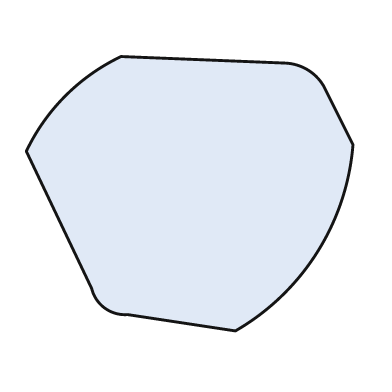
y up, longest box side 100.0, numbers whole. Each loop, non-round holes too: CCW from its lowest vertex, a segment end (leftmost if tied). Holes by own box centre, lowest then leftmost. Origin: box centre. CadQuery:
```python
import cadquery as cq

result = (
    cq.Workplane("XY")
    .moveTo(14.0, -42.0)
    .threePointArc((39.0, -18.0), (50.0, 15.0))
    .lineTo(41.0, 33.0)
    .threePointArc((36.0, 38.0), (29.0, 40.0))
    .lineTo(-21.0, 42.0)
    .threePointArc((-38.0, 30.0), (-50.0, 13.0))
    .lineTo(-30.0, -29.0)
    .threePointArc((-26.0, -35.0), (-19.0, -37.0))
    .close()
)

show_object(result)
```